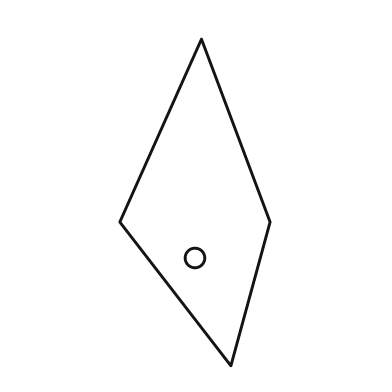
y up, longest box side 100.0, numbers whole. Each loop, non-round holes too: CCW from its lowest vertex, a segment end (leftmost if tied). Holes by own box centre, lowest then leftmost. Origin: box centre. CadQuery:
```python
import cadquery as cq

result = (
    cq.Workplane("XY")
    .moveTo(11.0, -50.0)
    .lineTo(23.0, -6.0)
    .lineTo(2.0, 50.0)
    .lineTo(-23.0, -6.0)
    .close()
    .moveTo(0.0, -17.0)
    .circle(3.0)
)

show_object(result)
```